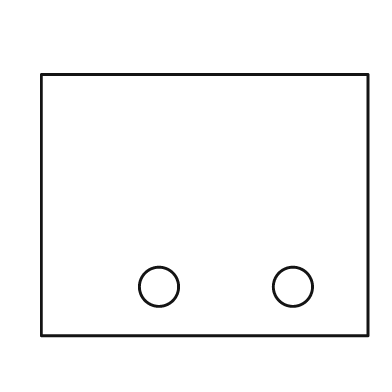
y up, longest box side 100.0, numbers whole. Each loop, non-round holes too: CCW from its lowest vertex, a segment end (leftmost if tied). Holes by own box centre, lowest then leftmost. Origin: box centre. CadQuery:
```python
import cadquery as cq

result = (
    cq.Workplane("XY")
    .moveTo(-50.0, -40.0)
    .lineTo(50.0, -40.0)
    .lineTo(50.0, 40.0)
    .lineTo(-50.0, 40.0)
    .close()
    .moveTo(-14.0, -25.0)
    .circle(6.0)
    .moveTo(27.0, -25.0)
    .circle(6.0)
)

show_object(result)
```